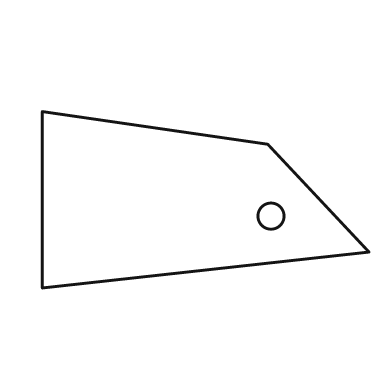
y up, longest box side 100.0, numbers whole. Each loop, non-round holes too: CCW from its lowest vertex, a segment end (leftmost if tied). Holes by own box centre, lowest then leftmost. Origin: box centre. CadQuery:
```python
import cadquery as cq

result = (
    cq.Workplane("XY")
    .moveTo(-50.0, -27.0)
    .lineTo(50.0, -16.0)
    .lineTo(19.0, 17.0)
    .lineTo(-50.0, 27.0)
    .close()
    .moveTo(20.0, -5.0)
    .circle(4.0)
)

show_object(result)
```